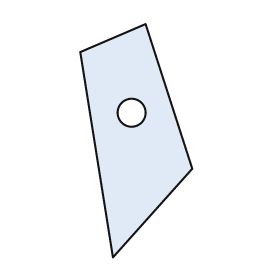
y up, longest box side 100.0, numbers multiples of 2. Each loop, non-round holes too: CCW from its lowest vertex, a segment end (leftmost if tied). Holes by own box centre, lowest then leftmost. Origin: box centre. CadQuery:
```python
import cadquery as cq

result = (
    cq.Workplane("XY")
    .moveTo(-10.0, -50.0)
    .lineTo(24.0, -12.0)
    .lineTo(4.0, 50.0)
    .lineTo(-24.0, 38.0)
    .close()
    .moveTo(-2.0, 12.0)
    .circle(6.0)
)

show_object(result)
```